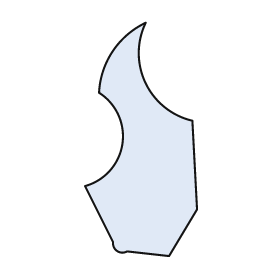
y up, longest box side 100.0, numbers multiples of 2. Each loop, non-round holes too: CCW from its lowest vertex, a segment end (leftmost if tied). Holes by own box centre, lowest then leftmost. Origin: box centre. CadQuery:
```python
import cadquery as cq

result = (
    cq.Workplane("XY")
    .moveTo(12.0, -50.0)
    .lineTo(24.0, -30.0)
    .lineTo(22.0, 8.0)
    .threePointArc((2.0, 24.0), (2.0, 50.0))
    .threePointArc((-12.0, 38.0), (-18.0, 20.0))
    .threePointArc((-8.0, -2.0), (-24.0, -20.0))
    .lineTo(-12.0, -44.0)
    .threePointArc((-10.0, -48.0), (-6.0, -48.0))
    .close()
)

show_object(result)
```